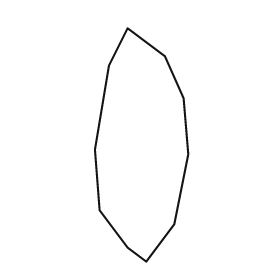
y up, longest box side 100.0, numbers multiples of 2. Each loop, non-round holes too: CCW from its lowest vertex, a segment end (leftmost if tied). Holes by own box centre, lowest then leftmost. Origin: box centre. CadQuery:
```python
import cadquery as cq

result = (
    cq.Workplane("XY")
    .moveTo(2.0, -50.0)
    .lineTo(14.0, -34.0)
    .lineTo(20.0, -4.0)
    .lineTo(18.0, 20.0)
    .lineTo(10.0, 38.0)
    .lineTo(-6.0, 50.0)
    .lineTo(-14.0, 34.0)
    .lineTo(-20.0, -2.0)
    .lineTo(-18.0, -28.0)
    .lineTo(-6.0, -44.0)
    .close()
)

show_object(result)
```